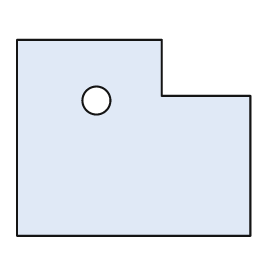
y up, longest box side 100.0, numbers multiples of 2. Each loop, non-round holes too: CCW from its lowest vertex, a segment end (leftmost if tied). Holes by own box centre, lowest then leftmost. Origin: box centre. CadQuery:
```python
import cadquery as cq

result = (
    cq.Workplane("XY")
    .moveTo(-50.0, -42.0)
    .lineTo(50.0, -42.0)
    .lineTo(50.0, 18.0)
    .lineTo(12.0, 18.0)
    .lineTo(12.0, 42.0)
    .lineTo(-50.0, 42.0)
    .close()
    .moveTo(-16.0, 16.0)
    .circle(6.0)
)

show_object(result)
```